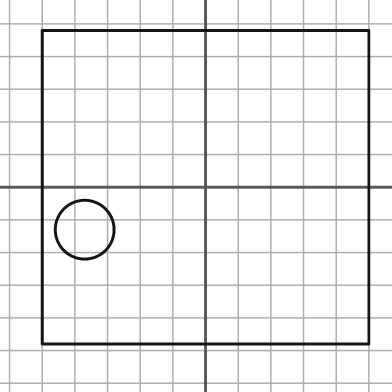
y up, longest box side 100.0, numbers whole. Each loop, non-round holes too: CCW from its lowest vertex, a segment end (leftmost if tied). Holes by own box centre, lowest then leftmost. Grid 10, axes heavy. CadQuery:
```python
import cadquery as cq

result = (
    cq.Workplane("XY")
    .moveTo(-50.0, -48.0)
    .lineTo(50.0, -48.0)
    .lineTo(50.0, 48.0)
    .lineTo(-50.0, 48.0)
    .close()
    .moveTo(-37.0, -13.0)
    .circle(9.0)
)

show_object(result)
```